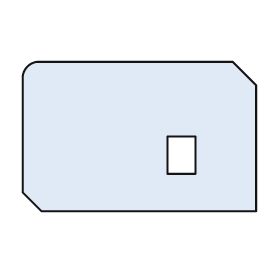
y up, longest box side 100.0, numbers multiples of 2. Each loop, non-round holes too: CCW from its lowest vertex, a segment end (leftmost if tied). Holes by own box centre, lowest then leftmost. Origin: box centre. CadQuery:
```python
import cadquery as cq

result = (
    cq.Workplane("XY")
    .moveTo(-42.0, -32.0)
    .lineTo(50.0, -32.0)
    .lineTo(50.0, 22.0)
    .lineTo(40.0, 32.0)
    .lineTo(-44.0, 32.0)
    .threePointArc((-48.0, 30.0), (-50.0, 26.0))
    .lineTo(-50.0, -24.0)
    .close()
    .moveTo(12.0, -16.0)
    .lineTo(24.0, -16.0)
    .lineTo(24.0, 0.0)
    .lineTo(12.0, 0.0)
    .close()
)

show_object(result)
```